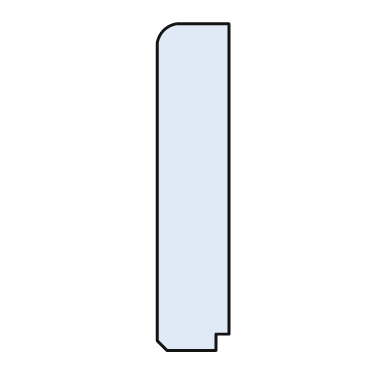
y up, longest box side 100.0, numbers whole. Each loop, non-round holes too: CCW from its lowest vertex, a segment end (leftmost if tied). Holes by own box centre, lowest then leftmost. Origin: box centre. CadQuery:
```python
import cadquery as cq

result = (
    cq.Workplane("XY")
    .moveTo(-8.0, -50.0)
    .lineTo(7.0, -50.0)
    .lineTo(7.0, -45.0)
    .lineTo(11.0, -45.0)
    .lineTo(11.0, 50.0)
    .lineTo(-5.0, 50.0)
    .threePointArc((-9.0, 48.0), (-11.0, 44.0))
    .lineTo(-11.0, -47.0)
    .close()
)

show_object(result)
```